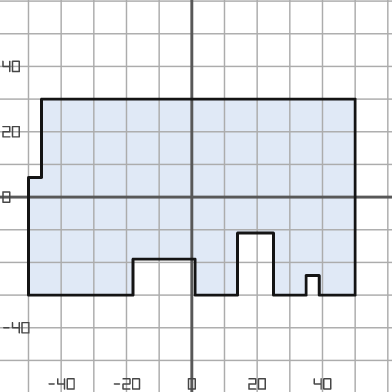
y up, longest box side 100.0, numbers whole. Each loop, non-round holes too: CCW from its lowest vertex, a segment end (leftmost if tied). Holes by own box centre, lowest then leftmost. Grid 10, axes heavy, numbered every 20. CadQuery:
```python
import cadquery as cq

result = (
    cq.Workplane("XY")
    .moveTo(-50.0, -30.0)
    .lineTo(-18.0, -30.0)
    .lineTo(-18.0, -19.0)
    .lineTo(1.0, -19.0)
    .lineTo(1.0, -30.0)
    .lineTo(14.0, -30.0)
    .lineTo(14.0, -11.0)
    .lineTo(25.0, -11.0)
    .lineTo(25.0, -30.0)
    .lineTo(35.0, -30.0)
    .lineTo(35.0, -24.0)
    .lineTo(39.0, -24.0)
    .lineTo(39.0, -30.0)
    .lineTo(50.0, -30.0)
    .lineTo(50.0, 30.0)
    .lineTo(-46.0, 30.0)
    .lineTo(-46.0, 6.0)
    .lineTo(-50.0, 6.0)
    .close()
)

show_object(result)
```